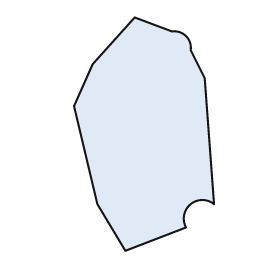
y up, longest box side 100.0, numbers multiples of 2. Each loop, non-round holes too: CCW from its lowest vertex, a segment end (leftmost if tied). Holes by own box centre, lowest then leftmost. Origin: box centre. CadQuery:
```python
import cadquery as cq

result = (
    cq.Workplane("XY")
    .moveTo(-8.0, -50.0)
    .lineTo(18.0, -40.0)
    .threePointArc((20.0, -30.0), (30.0, -30.0))
    .lineTo(26.0, 24.0)
    .lineTo(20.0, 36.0)
    .threePointArc((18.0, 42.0), (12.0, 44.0))
    .lineTo(-4.0, 50.0)
    .lineTo(-22.0, 30.0)
    .lineTo(-30.0, 12.0)
    .lineTo(-20.0, -30.0)
    .close()
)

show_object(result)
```